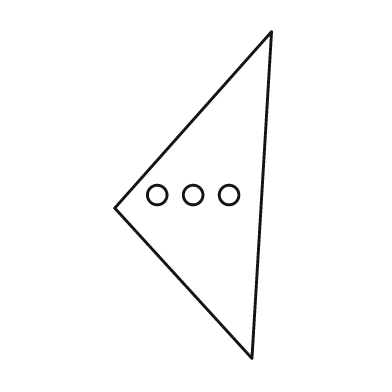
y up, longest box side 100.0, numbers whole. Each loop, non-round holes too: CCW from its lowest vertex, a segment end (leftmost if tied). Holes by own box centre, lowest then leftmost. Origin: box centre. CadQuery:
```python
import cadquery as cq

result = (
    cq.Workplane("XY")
    .moveTo(18.0, -50.0)
    .lineTo(24.0, 50.0)
    .lineTo(-24.0, -4.0)
    .close()
    .moveTo(-11.0, 0.0)
    .circle(3.0)
    .moveTo(0.0, 0.0)
    .circle(3.0)
    .moveTo(11.0, 0.0)
    .circle(3.0)
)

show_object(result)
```